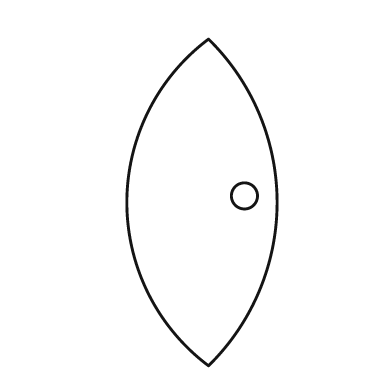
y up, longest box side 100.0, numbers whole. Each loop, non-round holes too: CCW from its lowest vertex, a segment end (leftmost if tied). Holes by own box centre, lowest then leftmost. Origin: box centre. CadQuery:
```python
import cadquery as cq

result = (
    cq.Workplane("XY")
    .moveTo(2.0, -50.0)
    .threePointArc((23.0, 0.0), (2.0, 50.0))
    .threePointArc((-23.0, 0.0), (2.0, -50.0))
    .close()
    .moveTo(13.0, 2.0)
    .circle(4.0)
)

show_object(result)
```